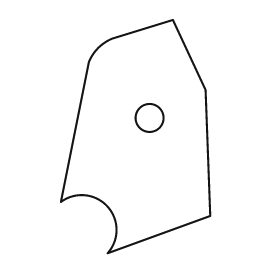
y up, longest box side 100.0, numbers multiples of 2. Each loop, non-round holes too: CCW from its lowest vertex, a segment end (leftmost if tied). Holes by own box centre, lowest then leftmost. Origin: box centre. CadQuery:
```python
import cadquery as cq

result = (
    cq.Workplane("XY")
    .moveTo(-12.0, -50.0)
    .lineTo(32.0, -34.0)
    .lineTo(30.0, 20.0)
    .lineTo(16.0, 50.0)
    .lineTo(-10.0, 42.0)
    .threePointArc((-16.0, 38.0), (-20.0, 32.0))
    .lineTo(-32.0, -28.0)
    .threePointArc((-12.0, -30.0), (-12.0, -50.0))
    .close()
    .moveTo(6.0, 8.0)
    .circle(6.0)
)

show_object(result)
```